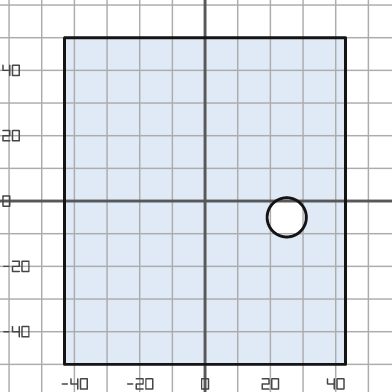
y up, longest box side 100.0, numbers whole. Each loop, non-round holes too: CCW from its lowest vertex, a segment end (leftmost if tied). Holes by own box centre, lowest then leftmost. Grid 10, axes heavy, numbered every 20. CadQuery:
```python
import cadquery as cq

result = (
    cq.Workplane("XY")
    .moveTo(-43.0, -50.0)
    .lineTo(43.0, -50.0)
    .lineTo(43.0, 50.0)
    .lineTo(-43.0, 50.0)
    .close()
    .moveTo(25.0, -5.0)
    .circle(6.0)
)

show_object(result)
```